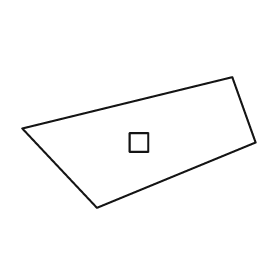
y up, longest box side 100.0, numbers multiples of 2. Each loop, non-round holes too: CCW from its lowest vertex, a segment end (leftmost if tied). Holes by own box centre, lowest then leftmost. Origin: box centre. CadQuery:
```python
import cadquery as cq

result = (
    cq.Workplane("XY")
    .moveTo(-18.0, -28.0)
    .lineTo(50.0, 0.0)
    .lineTo(40.0, 28.0)
    .lineTo(-50.0, 6.0)
    .close()
    .moveTo(-4.0, -4.0)
    .lineTo(4.0, -4.0)
    .lineTo(4.0, 4.0)
    .lineTo(-4.0, 4.0)
    .close()
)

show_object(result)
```